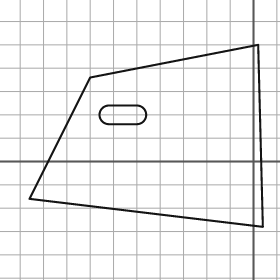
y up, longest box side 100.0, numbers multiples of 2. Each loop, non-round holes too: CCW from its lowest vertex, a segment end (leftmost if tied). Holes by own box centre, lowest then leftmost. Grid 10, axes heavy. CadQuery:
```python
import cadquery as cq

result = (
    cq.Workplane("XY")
    .moveTo(4.0, -28.0)
    .lineTo(2.0, 50.0)
    .lineTo(-70.0, 36.0)
    .lineTo(-96.0, -16.0)
    .close()
    .moveTo(-62.0, 16.0)
    .lineTo(-50.0, 16.0)
    .threePointArc((-46.0, 20.0), (-50.0, 24.0))
    .lineTo(-62.0, 24.0)
    .threePointArc((-66.0, 20.0), (-62.0, 16.0))
    .close()
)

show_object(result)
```